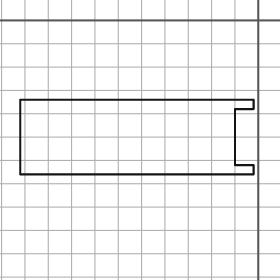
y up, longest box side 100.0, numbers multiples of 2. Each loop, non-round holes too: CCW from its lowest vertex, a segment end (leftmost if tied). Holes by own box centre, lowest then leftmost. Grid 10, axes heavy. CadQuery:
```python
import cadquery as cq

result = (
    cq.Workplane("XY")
    .moveTo(-102.0, -66.0)
    .lineTo(-2.0, -66.0)
    .lineTo(-2.0, -62.0)
    .lineTo(-10.0, -62.0)
    .lineTo(-10.0, -38.0)
    .lineTo(-2.0, -38.0)
    .lineTo(-2.0, -34.0)
    .lineTo(-102.0, -34.0)
    .close()
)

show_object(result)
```